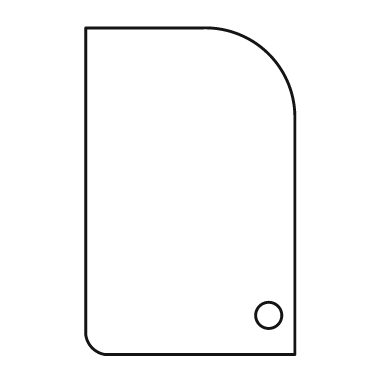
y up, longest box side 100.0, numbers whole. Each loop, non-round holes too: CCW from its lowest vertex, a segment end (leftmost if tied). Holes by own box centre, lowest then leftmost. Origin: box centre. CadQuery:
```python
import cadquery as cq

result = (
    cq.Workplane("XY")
    .moveTo(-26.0, -50.0)
    .lineTo(32.0, -50.0)
    .lineTo(32.0, 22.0)
    .threePointArc((24.0, 42.0), (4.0, 50.0))
    .lineTo(-32.0, 50.0)
    .lineTo(-32.0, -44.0)
    .threePointArc((-30.0, -48.0), (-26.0, -50.0))
    .close()
    .moveTo(24.0, -38.0)
    .circle(4.0)
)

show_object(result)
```